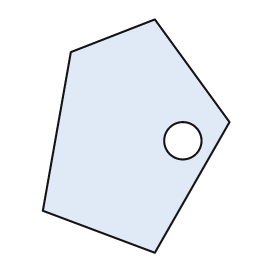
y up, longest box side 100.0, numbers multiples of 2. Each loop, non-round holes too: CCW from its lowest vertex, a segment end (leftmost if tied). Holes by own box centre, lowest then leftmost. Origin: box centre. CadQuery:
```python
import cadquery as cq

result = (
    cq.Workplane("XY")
    .moveTo(8.0, -50.0)
    .lineTo(40.0, 6.0)
    .lineTo(8.0, 50.0)
    .lineTo(-28.0, 36.0)
    .lineTo(-40.0, -32.0)
    .close()
    .moveTo(20.0, -2.0)
    .circle(8.0)
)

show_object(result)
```